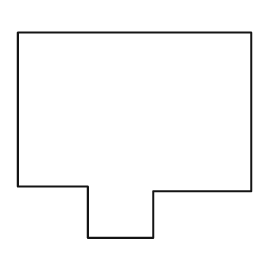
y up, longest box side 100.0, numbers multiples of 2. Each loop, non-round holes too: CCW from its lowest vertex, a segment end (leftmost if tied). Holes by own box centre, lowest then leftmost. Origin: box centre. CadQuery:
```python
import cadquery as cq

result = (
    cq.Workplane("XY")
    .moveTo(-20.0, -44.0)
    .lineTo(8.0, -44.0)
    .lineTo(8.0, -24.0)
    .lineTo(50.0, -24.0)
    .lineTo(50.0, 44.0)
    .lineTo(-50.0, 44.0)
    .lineTo(-50.0, -22.0)
    .lineTo(-20.0, -22.0)
    .close()
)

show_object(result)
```